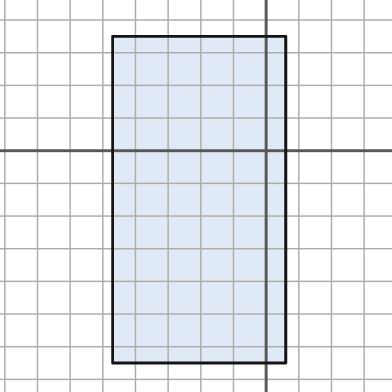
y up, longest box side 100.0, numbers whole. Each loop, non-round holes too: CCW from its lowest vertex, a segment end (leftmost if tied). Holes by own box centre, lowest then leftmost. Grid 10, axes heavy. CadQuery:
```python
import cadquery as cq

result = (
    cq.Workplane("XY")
    .moveTo(-47.0, -65.0)
    .lineTo(6.0, -65.0)
    .lineTo(6.0, 35.0)
    .lineTo(-47.0, 35.0)
    .close()
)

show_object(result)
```